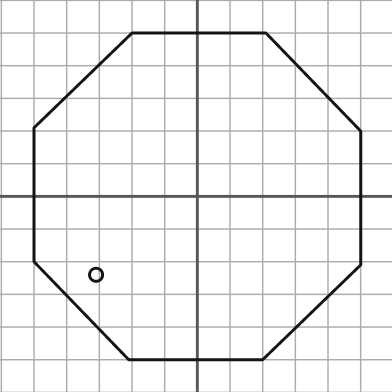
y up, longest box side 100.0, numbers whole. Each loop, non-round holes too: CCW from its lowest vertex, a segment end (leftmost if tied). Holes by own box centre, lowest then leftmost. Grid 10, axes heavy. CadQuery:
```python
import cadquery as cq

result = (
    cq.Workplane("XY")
    .moveTo(-21.0, -50.0)
    .lineTo(20.0, -50.0)
    .lineTo(50.0, -21.0)
    .lineTo(50.0, 20.0)
    .lineTo(21.0, 50.0)
    .lineTo(-20.0, 50.0)
    .lineTo(-50.0, 21.0)
    .lineTo(-50.0, -20.0)
    .close()
    .moveTo(-31.0, -24.0)
    .circle(2.0)
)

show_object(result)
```